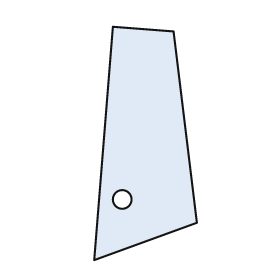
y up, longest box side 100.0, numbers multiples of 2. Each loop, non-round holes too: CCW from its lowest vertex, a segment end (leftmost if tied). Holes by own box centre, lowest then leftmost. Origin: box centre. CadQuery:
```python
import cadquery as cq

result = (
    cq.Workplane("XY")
    .moveTo(-22.0, -50.0)
    .lineTo(22.0, -34.0)
    .lineTo(12.0, 48.0)
    .lineTo(-14.0, 50.0)
    .close()
    .moveTo(-10.0, -24.0)
    .circle(4.0)
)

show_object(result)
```